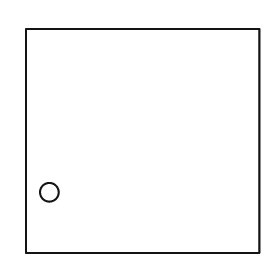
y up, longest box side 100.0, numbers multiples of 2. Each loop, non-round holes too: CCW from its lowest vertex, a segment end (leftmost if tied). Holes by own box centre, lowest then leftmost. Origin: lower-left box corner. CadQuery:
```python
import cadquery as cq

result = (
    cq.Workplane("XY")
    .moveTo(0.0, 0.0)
    .lineTo(100.0, 0.0)
    .lineTo(100.0, 96.0)
    .lineTo(0.0, 96.0)
    .close()
    .moveTo(10.0, 26.0)
    .circle(4.0)
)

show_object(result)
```